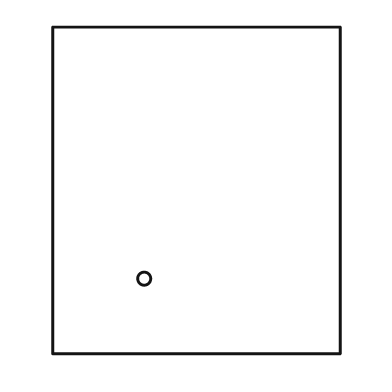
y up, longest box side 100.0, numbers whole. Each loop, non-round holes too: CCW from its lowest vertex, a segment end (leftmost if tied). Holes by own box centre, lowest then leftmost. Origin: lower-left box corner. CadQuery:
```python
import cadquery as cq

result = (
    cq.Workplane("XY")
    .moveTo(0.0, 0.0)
    .lineTo(88.0, 0.0)
    .lineTo(88.0, 100.0)
    .lineTo(0.0, 100.0)
    .close()
    .moveTo(28.0, 23.0)
    .circle(2.0)
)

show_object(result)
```